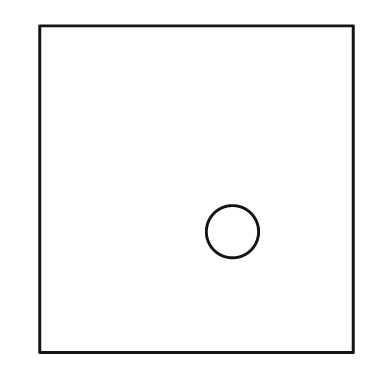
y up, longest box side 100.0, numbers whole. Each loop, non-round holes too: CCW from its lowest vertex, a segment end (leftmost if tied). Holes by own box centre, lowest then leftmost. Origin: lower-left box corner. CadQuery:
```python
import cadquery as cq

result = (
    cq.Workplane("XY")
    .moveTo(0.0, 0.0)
    .lineTo(96.0, 0.0)
    .lineTo(96.0, 100.0)
    .lineTo(0.0, 100.0)
    .close()
    .moveTo(59.0, 37.0)
    .circle(8.0)
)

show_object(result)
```